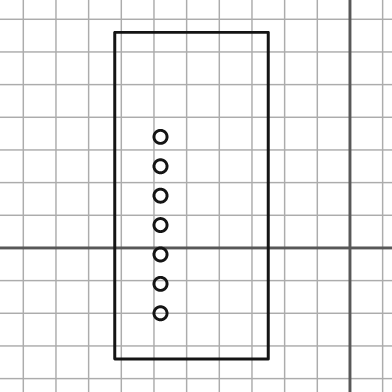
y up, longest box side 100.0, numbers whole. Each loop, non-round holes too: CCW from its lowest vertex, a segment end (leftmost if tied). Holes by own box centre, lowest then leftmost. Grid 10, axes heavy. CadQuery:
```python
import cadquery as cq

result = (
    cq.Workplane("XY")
    .moveTo(-72.0, -34.0)
    .lineTo(-25.0, -34.0)
    .lineTo(-25.0, 66.0)
    .lineTo(-72.0, 66.0)
    .close()
    .moveTo(-58.0, -20.0)
    .circle(2.0)
    .moveTo(-58.0, -11.0)
    .circle(2.0)
    .moveTo(-58.0, -2.0)
    .circle(2.0)
    .moveTo(-58.0, 7.0)
    .circle(2.0)
    .moveTo(-58.0, 16.0)
    .circle(2.0)
    .moveTo(-58.0, 25.0)
    .circle(2.0)
    .moveTo(-58.0, 34.0)
    .circle(2.0)
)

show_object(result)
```